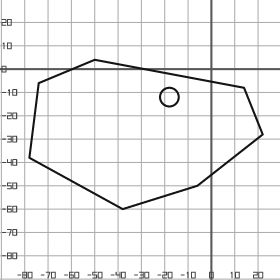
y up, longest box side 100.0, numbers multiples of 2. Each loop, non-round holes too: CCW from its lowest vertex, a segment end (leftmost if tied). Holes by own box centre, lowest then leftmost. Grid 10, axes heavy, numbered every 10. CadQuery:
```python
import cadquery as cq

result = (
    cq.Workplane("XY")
    .moveTo(-38.0, -60.0)
    .lineTo(-6.0, -50.0)
    .lineTo(22.0, -28.0)
    .lineTo(14.0, -8.0)
    .lineTo(-50.0, 4.0)
    .lineTo(-74.0, -6.0)
    .lineTo(-78.0, -38.0)
    .close()
    .moveTo(-18.0, -12.0)
    .circle(4.0)
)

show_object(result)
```